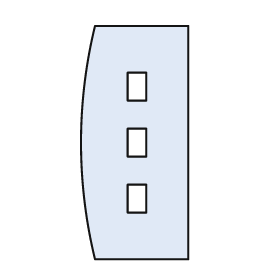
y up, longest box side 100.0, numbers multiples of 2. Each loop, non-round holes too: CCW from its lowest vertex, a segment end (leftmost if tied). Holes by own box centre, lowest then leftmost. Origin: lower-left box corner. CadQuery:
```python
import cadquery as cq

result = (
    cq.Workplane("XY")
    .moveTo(6.0, 0.0)
    .lineTo(46.0, 0.0)
    .lineTo(46.0, 100.0)
    .lineTo(6.0, 100.0)
    .threePointArc((0.0, 50.0), (6.0, 0.0))
    .close()
    .moveTo(20.0, 20.0)
    .lineTo(28.0, 20.0)
    .lineTo(28.0, 32.0)
    .lineTo(20.0, 32.0)
    .close()
    .moveTo(20.0, 44.0)
    .lineTo(28.0, 44.0)
    .lineTo(28.0, 56.0)
    .lineTo(20.0, 56.0)
    .close()
    .moveTo(20.0, 68.0)
    .lineTo(28.0, 68.0)
    .lineTo(28.0, 80.0)
    .lineTo(20.0, 80.0)
    .close()
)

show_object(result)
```